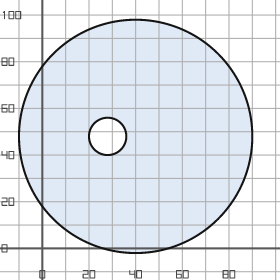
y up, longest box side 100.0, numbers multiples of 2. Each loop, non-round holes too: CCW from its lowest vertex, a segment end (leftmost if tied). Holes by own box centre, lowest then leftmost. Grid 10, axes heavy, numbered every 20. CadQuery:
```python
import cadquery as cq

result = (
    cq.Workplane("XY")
    .moveTo(40.0, 48.0)
    .circle(50.0)
    .moveTo(28.0, 48.0)
    .circle(8.0)
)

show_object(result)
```